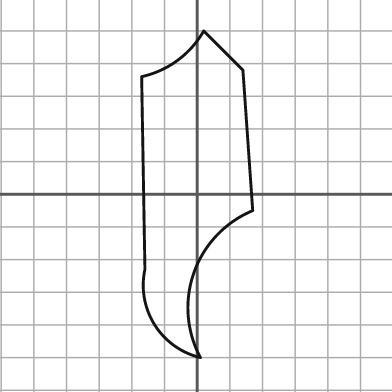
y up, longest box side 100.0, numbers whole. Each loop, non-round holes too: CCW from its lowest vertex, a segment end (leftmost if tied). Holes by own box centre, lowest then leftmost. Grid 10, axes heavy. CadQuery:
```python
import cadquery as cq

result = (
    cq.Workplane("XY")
    .moveTo(1.0, -50.0)
    .threePointArc((-1.0, -24.0), (17.0, -5.0))
    .lineTo(14.0, 38.0)
    .lineTo(2.0, 50.0)
    .threePointArc((-6.0, 41.0), (-17.0, 36.0))
    .lineTo(-16.0, -23.0)
    .threePointArc((-13.0, -40.0), (1.0, -50.0))
    .close()
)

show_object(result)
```